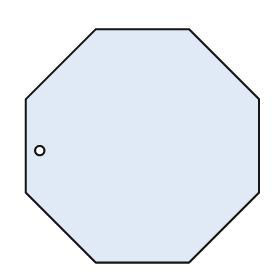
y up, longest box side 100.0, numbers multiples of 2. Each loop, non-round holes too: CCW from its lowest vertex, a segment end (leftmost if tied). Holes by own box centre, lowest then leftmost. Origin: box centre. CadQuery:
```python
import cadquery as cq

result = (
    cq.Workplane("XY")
    .moveTo(-20.0, -50.0)
    .lineTo(20.0, -50.0)
    .lineTo(50.0, -20.0)
    .lineTo(50.0, 20.0)
    .lineTo(20.0, 50.0)
    .lineTo(-20.0, 50.0)
    .lineTo(-50.0, 20.0)
    .lineTo(-50.0, -20.0)
    .close()
    .moveTo(-44.0, -2.0)
    .circle(2.0)
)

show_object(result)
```